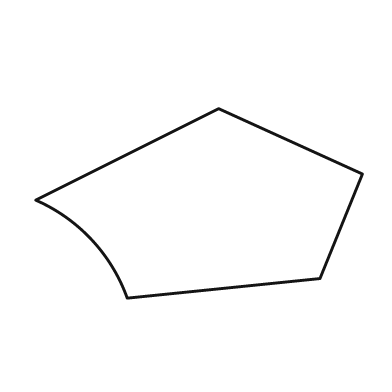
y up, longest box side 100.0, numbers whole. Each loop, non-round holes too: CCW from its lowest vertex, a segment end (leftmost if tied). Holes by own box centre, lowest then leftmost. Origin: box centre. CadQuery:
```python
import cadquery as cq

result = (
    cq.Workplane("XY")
    .moveTo(-22.0, -29.0)
    .lineTo(37.0, -23.0)
    .lineTo(50.0, 9.0)
    .lineTo(6.0, 29.0)
    .lineTo(-50.0, 1.0)
    .threePointArc((-33.0, -11.0), (-22.0, -29.0))
    .close()
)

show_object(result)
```